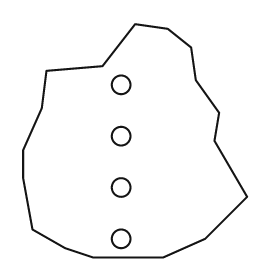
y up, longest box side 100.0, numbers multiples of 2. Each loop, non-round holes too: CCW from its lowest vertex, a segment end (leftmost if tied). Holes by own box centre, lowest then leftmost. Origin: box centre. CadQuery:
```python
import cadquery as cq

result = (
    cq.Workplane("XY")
    .moveTo(-18.0, -50.0)
    .lineTo(12.0, -50.0)
    .lineTo(30.0, -42.0)
    .lineTo(48.0, -24.0)
    .lineTo(34.0, 0.0)
    .lineTo(36.0, 12.0)
    .lineTo(26.0, 26.0)
    .lineTo(24.0, 40.0)
    .lineTo(14.0, 48.0)
    .lineTo(0.0, 50.0)
    .lineTo(-14.0, 32.0)
    .lineTo(-38.0, 30.0)
    .lineTo(-40.0, 14.0)
    .lineTo(-48.0, -4.0)
    .lineTo(-48.0, -16.0)
    .lineTo(-44.0, -38.0)
    .lineTo(-30.0, -46.0)
    .close()
    .moveTo(-6.0, -42.0)
    .circle(4.0)
    .moveTo(-6.0, -20.0)
    .circle(4.0)
    .moveTo(-6.0, 2.0)
    .circle(4.0)
    .moveTo(-6.0, 24.0)
    .circle(4.0)
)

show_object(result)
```